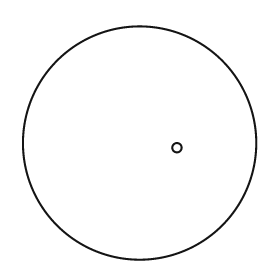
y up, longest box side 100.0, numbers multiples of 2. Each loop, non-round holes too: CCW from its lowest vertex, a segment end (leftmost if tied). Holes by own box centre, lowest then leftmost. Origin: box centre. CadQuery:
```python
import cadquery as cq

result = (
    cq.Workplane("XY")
    .moveTo(0.0, 0.0)
    .circle(50.0)
    .moveTo(16.0, -2.0)
    .circle(2.0)
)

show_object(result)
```